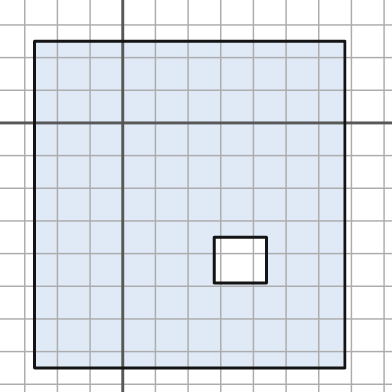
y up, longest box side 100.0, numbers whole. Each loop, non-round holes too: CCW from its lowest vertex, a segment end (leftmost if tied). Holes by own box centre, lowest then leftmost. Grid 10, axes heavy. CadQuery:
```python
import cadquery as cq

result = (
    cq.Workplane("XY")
    .moveTo(-27.0, -75.0)
    .lineTo(68.0, -75.0)
    .lineTo(68.0, 25.0)
    .lineTo(-27.0, 25.0)
    .close()
    .moveTo(28.0, -49.0)
    .lineTo(44.0, -49.0)
    .lineTo(44.0, -35.0)
    .lineTo(28.0, -35.0)
    .close()
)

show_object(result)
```